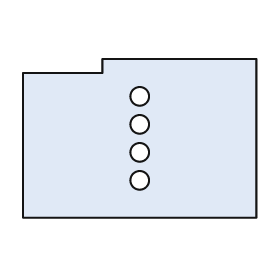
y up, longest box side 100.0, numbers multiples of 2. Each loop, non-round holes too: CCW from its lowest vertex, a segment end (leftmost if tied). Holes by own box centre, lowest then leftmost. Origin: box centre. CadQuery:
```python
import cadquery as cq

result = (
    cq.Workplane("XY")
    .moveTo(-50.0, -34.0)
    .lineTo(50.0, -34.0)
    .lineTo(50.0, 34.0)
    .lineTo(-16.0, 34.0)
    .lineTo(-16.0, 28.0)
    .lineTo(-50.0, 28.0)
    .close()
    .moveTo(0.0, -18.0)
    .circle(4.0)
    .moveTo(0.0, -6.0)
    .circle(4.0)
    .moveTo(0.0, 6.0)
    .circle(4.0)
    .moveTo(0.0, 18.0)
    .circle(4.0)
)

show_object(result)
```